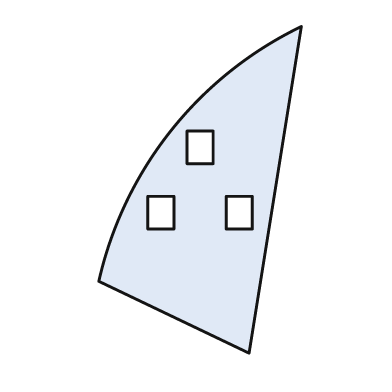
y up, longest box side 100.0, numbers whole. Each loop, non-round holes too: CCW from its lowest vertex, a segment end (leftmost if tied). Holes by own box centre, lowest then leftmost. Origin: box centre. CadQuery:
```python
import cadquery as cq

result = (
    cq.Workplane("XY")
    .moveTo(15.0, -50.0)
    .lineTo(31.0, 50.0)
    .threePointArc((-9.0, 18.0), (-31.0, -28.0))
    .close()
    .moveTo(-16.0, -12.0)
    .lineTo(-8.0, -12.0)
    .lineTo(-8.0, -2.0)
    .lineTo(-16.0, -2.0)
    .close()
    .moveTo(8.0, -12.0)
    .lineTo(16.0, -12.0)
    .lineTo(16.0, -2.0)
    .lineTo(8.0, -2.0)
    .close()
    .moveTo(-4.0, 8.0)
    .lineTo(4.0, 8.0)
    .lineTo(4.0, 18.0)
    .lineTo(-4.0, 18.0)
    .close()
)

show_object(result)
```